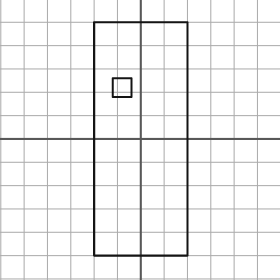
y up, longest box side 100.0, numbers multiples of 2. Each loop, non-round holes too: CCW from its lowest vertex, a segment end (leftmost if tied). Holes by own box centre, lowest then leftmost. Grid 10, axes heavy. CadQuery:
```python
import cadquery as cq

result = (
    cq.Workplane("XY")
    .moveTo(-20.0, -50.0)
    .lineTo(20.0, -50.0)
    .lineTo(20.0, 50.0)
    .lineTo(-20.0, 50.0)
    .close()
    .moveTo(-12.0, 18.0)
    .lineTo(-4.0, 18.0)
    .lineTo(-4.0, 26.0)
    .lineTo(-12.0, 26.0)
    .close()
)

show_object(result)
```